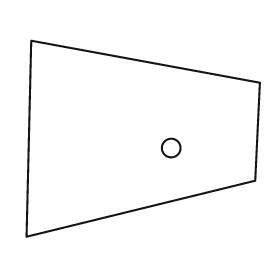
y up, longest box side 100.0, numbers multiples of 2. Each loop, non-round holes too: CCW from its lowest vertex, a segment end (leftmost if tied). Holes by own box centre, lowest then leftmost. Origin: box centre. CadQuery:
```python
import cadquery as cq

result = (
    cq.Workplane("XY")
    .moveTo(-50.0, -42.0)
    .lineTo(48.0, -18.0)
    .lineTo(50.0, 24.0)
    .lineTo(-48.0, 42.0)
    .close()
    .moveTo(12.0, -4.0)
    .circle(4.0)
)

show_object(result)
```